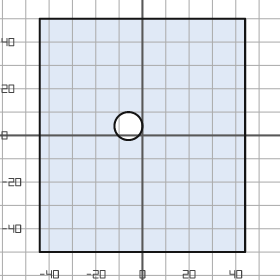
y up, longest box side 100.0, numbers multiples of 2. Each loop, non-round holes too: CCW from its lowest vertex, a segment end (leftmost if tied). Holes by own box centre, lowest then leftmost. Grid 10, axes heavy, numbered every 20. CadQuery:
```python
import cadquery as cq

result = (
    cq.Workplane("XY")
    .moveTo(-44.0, -50.0)
    .lineTo(44.0, -50.0)
    .lineTo(44.0, 50.0)
    .lineTo(-44.0, 50.0)
    .close()
    .moveTo(-6.0, 4.0)
    .circle(6.0)
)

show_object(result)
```